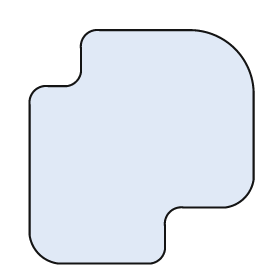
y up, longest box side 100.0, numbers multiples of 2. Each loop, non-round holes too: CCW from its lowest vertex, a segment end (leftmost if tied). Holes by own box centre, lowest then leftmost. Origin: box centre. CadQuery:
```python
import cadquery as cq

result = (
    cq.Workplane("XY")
    .moveTo(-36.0, -50.0)
    .lineTo(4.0, -50.0)
    .threePointArc((8.0, -48.0), (10.0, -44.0))
    .lineTo(10.0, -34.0)
    .threePointArc((12.0, -28.0), (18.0, -26.0))
    .lineTo(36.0, -26.0)
    .threePointArc((44.0, -22.0), (48.0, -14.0))
    .lineTo(48.0, 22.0)
    .threePointArc((40.0, 42.0), (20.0, 50.0))
    .lineTo(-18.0, 50.0)
    .threePointArc((-24.0, 48.0), (-26.0, 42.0))
    .lineTo(-26.0, 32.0)
    .threePointArc((-28.0, 28.0), (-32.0, 26.0))
    .lineTo(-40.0, 26.0)
    .threePointArc((-46.0, 24.0), (-48.0, 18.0))
    .lineTo(-48.0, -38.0)
    .threePointArc((-44.0, -46.0), (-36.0, -50.0))
    .close()
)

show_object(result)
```